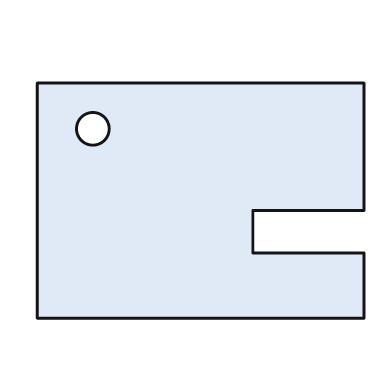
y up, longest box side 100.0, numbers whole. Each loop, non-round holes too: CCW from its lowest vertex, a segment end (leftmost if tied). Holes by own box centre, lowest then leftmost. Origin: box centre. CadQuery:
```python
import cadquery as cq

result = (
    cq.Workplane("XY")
    .moveTo(-50.0, -36.0)
    .lineTo(50.0, -36.0)
    .lineTo(50.0, -16.0)
    .lineTo(16.0, -16.0)
    .lineTo(16.0, -3.0)
    .lineTo(50.0, -3.0)
    .lineTo(50.0, 36.0)
    .lineTo(-50.0, 36.0)
    .close()
    .moveTo(-33.0, 22.0)
    .circle(5.0)
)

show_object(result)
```